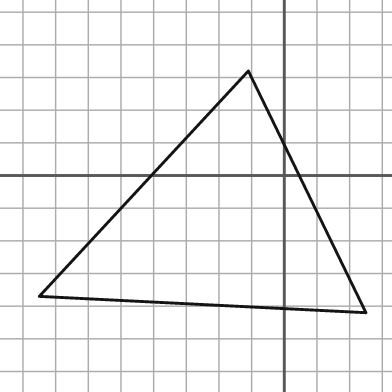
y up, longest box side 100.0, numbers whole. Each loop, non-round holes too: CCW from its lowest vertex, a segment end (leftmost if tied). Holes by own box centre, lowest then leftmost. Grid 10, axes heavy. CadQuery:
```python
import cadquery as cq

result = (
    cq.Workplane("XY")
    .moveTo(25.0, -42.0)
    .lineTo(-11.0, 32.0)
    .lineTo(-75.0, -37.0)
    .close()
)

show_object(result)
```